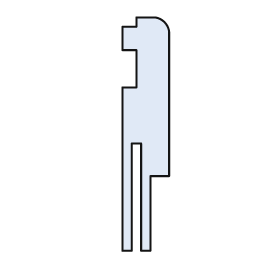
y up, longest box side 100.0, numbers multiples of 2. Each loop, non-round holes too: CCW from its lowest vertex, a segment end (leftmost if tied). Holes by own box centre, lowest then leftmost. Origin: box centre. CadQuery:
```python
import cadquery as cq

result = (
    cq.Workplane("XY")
    .moveTo(-10.0, -50.0)
    .lineTo(-6.0, -50.0)
    .lineTo(-6.0, -4.0)
    .lineTo(-2.0, -4.0)
    .lineTo(-2.0, -50.0)
    .lineTo(2.0, -50.0)
    .lineTo(2.0, -18.0)
    .lineTo(10.0, -18.0)
    .lineTo(10.0, 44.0)
    .threePointArc((8.0, 48.0), (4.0, 50.0))
    .lineTo(-4.0, 50.0)
    .lineTo(-4.0, 46.0)
    .lineTo(-10.0, 46.0)
    .lineTo(-10.0, 36.0)
    .lineTo(-4.0, 36.0)
    .lineTo(-4.0, 20.0)
    .lineTo(-10.0, 20.0)
    .close()
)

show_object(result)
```